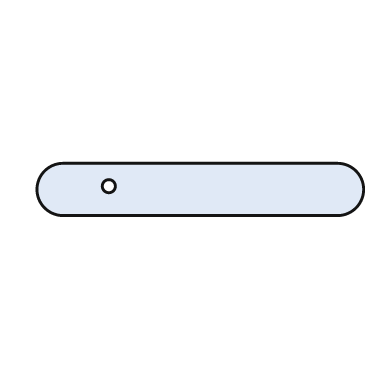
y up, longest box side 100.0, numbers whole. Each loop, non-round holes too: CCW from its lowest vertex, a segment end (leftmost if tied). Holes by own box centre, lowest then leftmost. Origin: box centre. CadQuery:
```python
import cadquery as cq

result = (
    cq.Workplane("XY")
    .moveTo(-42.0, -8.0)
    .lineTo(42.0, -8.0)
    .threePointArc((50.0, 0.0), (42.0, 8.0))
    .lineTo(-42.0, 8.0)
    .threePointArc((-50.0, 0.0), (-42.0, -8.0))
    .close()
    .moveTo(-28.0, 1.0)
    .circle(2.0)
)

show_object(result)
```